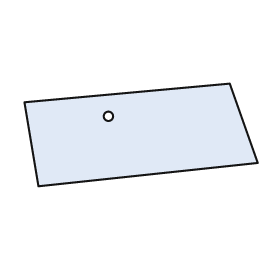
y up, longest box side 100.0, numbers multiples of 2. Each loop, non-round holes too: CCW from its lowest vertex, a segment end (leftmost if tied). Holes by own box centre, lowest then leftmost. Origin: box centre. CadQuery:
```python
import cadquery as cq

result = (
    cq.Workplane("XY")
    .moveTo(-44.0, -22.0)
    .lineTo(50.0, -12.0)
    .lineTo(38.0, 22.0)
    .lineTo(-50.0, 14.0)
    .close()
    .moveTo(-14.0, 8.0)
    .circle(2.0)
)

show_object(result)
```